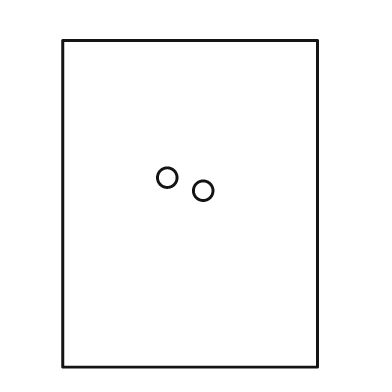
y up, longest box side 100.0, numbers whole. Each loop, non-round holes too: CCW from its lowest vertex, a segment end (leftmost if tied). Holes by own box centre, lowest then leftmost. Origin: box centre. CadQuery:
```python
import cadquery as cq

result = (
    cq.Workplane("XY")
    .moveTo(-39.0, -50.0)
    .lineTo(39.0, -50.0)
    .lineTo(39.0, 50.0)
    .lineTo(-39.0, 50.0)
    .close()
    .moveTo(4.0, 4.0)
    .circle(3.0)
    .moveTo(-7.0, 8.0)
    .circle(3.0)
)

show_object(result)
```